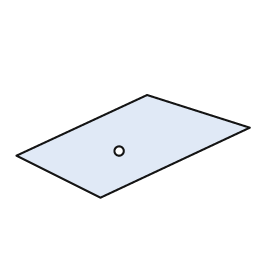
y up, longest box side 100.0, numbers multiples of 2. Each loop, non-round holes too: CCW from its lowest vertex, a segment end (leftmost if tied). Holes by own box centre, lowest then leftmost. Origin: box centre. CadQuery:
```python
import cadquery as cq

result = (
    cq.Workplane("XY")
    .moveTo(-14.0, -22.0)
    .lineTo(50.0, 8.0)
    .lineTo(6.0, 22.0)
    .lineTo(-50.0, -4.0)
    .close()
    .moveTo(-6.0, -2.0)
    .circle(2.0)
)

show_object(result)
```